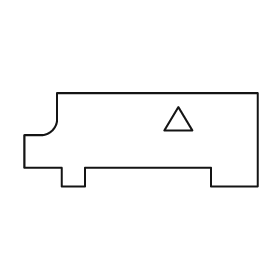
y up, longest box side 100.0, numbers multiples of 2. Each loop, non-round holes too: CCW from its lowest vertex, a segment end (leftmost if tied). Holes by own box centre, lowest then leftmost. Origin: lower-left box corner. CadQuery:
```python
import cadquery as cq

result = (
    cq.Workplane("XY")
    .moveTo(16.0, 0.0)
    .lineTo(26.0, 0.0)
    .lineTo(26.0, 8.0)
    .lineTo(80.0, 8.0)
    .lineTo(80.0, 0.0)
    .lineTo(100.0, 0.0)
    .lineTo(100.0, 40.0)
    .lineTo(14.0, 40.0)
    .lineTo(14.0, 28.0)
    .threePointArc((12.0, 24.0), (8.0, 22.0))
    .lineTo(0.0, 22.0)
    .lineTo(0.0, 8.0)
    .lineTo(16.0, 8.0)
    .close()
    .moveTo(60.0, 24.0)
    .lineTo(72.0, 24.0)
    .lineTo(66.0, 34.0)
    .close()
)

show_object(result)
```